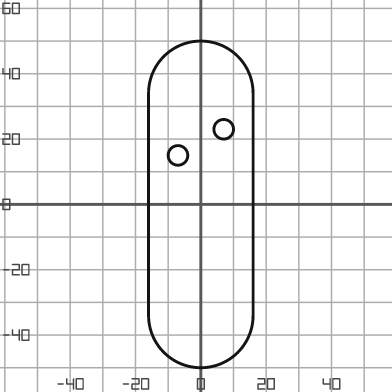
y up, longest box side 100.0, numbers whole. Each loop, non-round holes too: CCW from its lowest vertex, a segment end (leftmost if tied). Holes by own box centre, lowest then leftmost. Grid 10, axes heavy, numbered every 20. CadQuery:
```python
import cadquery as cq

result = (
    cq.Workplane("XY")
    .moveTo(-16.0, -34.0)
    .threePointArc((0.0, -50.0), (16.0, -34.0))
    .lineTo(16.0, 34.0)
    .threePointArc((0.0, 50.0), (-16.0, 34.0))
    .close()
    .moveTo(-7.0, 15.0)
    .circle(3.0)
    .moveTo(7.0, 23.0)
    .circle(3.0)
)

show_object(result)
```